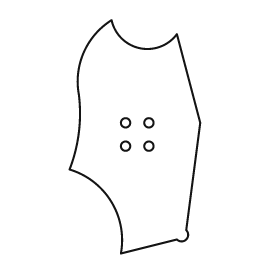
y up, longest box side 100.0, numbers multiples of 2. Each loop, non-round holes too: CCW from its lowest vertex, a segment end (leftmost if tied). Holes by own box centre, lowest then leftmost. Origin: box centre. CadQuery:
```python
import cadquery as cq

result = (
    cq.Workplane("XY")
    .moveTo(-6.0, -50.0)
    .lineTo(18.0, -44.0)
    .threePointArc((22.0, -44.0), (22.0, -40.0))
    .lineTo(28.0, 6.0)
    .lineTo(18.0, 44.0)
    .threePointArc((2.0, 38.0), (-10.0, 50.0))
    .threePointArc((-22.0, 36.0), (-24.0, 18.0))
    .threePointArc((-24.0, 2.0), (-28.0, -14.0))
    .threePointArc((-10.0, -28.0), (-6.0, -50.0))
    .close()
    .moveTo(-4.0, -4.0)
    .circle(2.0)
    .moveTo(6.0, -4.0)
    .circle(2.0)
    .moveTo(-4.0, 6.0)
    .circle(2.0)
    .moveTo(6.0, 6.0)
    .circle(2.0)
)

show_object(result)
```